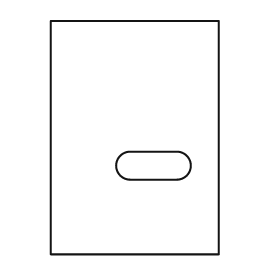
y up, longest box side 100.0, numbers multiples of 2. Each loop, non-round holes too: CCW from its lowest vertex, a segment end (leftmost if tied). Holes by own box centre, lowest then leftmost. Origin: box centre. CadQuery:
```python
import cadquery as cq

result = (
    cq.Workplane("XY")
    .moveTo(-36.0, -50.0)
    .lineTo(36.0, -50.0)
    .lineTo(36.0, 50.0)
    .lineTo(-36.0, 50.0)
    .close()
    .moveTo(-2.0, -18.0)
    .lineTo(18.0, -18.0)
    .threePointArc((24.0, -12.0), (18.0, -6.0))
    .lineTo(-2.0, -6.0)
    .threePointArc((-8.0, -12.0), (-2.0, -18.0))
    .close()
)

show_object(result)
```